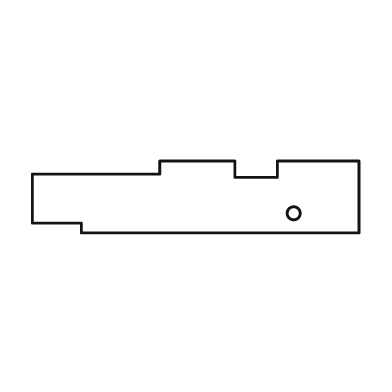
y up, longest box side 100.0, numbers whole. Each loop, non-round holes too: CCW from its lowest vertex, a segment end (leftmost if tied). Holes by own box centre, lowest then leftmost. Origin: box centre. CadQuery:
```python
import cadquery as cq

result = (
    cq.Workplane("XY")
    .moveTo(-35.0, -11.0)
    .lineTo(50.0, -11.0)
    .lineTo(50.0, 11.0)
    .lineTo(25.0, 11.0)
    .lineTo(25.0, 6.0)
    .lineTo(12.0, 6.0)
    .lineTo(12.0, 11.0)
    .lineTo(-11.0, 11.0)
    .lineTo(-11.0, 7.0)
    .lineTo(-50.0, 7.0)
    .lineTo(-50.0, -8.0)
    .lineTo(-35.0, -8.0)
    .close()
    .moveTo(30.0, -5.0)
    .circle(2.0)
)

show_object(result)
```